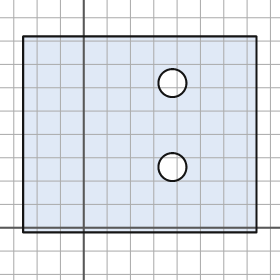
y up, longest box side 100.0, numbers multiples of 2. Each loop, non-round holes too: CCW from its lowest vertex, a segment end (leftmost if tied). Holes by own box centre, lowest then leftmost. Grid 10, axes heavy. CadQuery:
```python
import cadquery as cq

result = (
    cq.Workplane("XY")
    .moveTo(-26.0, -2.0)
    .lineTo(74.0, -2.0)
    .lineTo(74.0, 82.0)
    .lineTo(-26.0, 82.0)
    .close()
    .moveTo(38.0, 26.0)
    .circle(6.0)
    .moveTo(38.0, 62.0)
    .circle(6.0)
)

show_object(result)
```